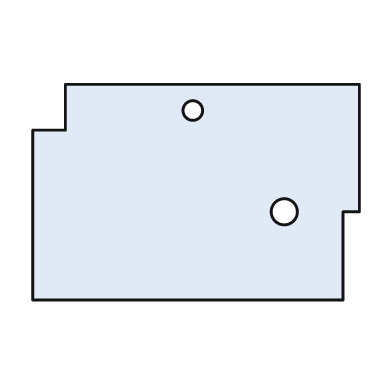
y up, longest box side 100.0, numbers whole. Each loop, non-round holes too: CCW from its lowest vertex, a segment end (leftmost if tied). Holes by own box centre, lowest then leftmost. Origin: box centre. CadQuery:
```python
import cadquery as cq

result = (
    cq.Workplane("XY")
    .moveTo(-50.0, -33.0)
    .lineTo(45.0, -33.0)
    .lineTo(45.0, -6.0)
    .lineTo(50.0, -6.0)
    .lineTo(50.0, 33.0)
    .lineTo(-40.0, 33.0)
    .lineTo(-40.0, 19.0)
    .lineTo(-50.0, 19.0)
    .close()
    .moveTo(27.0, -6.0)
    .circle(4.0)
    .moveTo(-1.0, 25.0)
    .circle(3.0)
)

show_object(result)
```